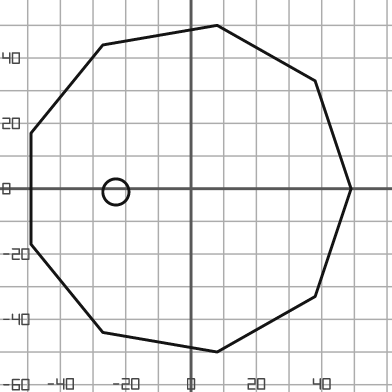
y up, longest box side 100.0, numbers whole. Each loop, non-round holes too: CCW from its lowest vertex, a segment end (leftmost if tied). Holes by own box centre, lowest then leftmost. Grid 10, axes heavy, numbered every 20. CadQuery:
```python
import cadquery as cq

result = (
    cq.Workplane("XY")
    .moveTo(8.0, -50.0)
    .lineTo(38.0, -33.0)
    .lineTo(49.0, 0.0)
    .lineTo(38.0, 33.0)
    .lineTo(8.0, 50.0)
    .lineTo(-27.0, 44.0)
    .lineTo(-49.0, 17.0)
    .lineTo(-49.0, -17.0)
    .lineTo(-27.0, -44.0)
    .close()
    .moveTo(-23.0, -1.0)
    .circle(4.0)
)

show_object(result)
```